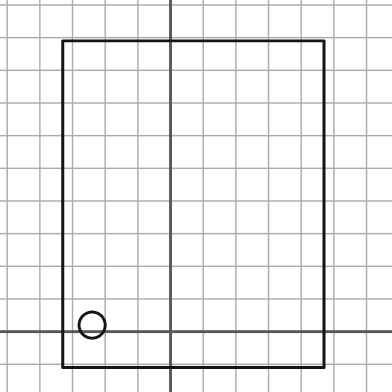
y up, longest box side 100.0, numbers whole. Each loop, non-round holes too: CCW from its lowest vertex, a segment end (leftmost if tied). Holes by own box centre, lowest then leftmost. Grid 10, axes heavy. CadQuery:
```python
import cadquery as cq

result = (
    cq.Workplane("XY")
    .moveTo(-33.0, -11.0)
    .lineTo(47.0, -11.0)
    .lineTo(47.0, 89.0)
    .lineTo(-33.0, 89.0)
    .close()
    .moveTo(-24.0, 2.0)
    .circle(4.0)
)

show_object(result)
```